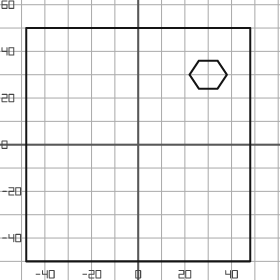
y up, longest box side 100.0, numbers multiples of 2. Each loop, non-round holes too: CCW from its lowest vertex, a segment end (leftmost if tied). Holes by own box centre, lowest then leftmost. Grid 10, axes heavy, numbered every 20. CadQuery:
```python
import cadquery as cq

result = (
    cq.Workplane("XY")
    .moveTo(-48.0, -50.0)
    .lineTo(48.0, -50.0)
    .lineTo(48.0, 50.0)
    .lineTo(-48.0, 50.0)
    .close()
    .moveTo(26.0, 24.0)
    .lineTo(34.0, 24.0)
    .lineTo(38.0, 30.0)
    .lineTo(34.0, 36.0)
    .lineTo(26.0, 36.0)
    .lineTo(22.0, 30.0)
    .close()
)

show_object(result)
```